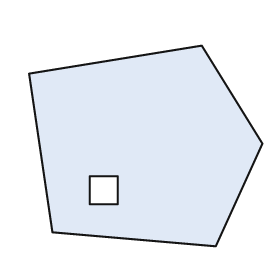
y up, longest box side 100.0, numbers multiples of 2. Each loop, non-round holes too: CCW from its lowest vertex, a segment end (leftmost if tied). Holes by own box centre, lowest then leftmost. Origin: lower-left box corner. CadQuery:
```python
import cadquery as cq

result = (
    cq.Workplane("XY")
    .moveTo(80.0, 0.0)
    .lineTo(100.0, 44.0)
    .lineTo(74.0, 86.0)
    .lineTo(0.0, 74.0)
    .lineTo(10.0, 6.0)
    .close()
    .moveTo(26.0, 18.0)
    .lineTo(38.0, 18.0)
    .lineTo(38.0, 30.0)
    .lineTo(26.0, 30.0)
    .close()
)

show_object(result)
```